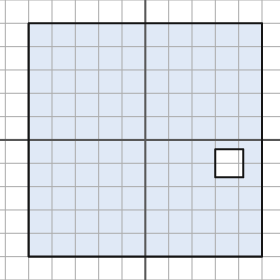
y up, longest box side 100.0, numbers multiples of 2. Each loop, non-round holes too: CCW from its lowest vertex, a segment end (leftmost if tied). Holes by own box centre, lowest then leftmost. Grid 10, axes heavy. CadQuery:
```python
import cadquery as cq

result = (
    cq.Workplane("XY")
    .moveTo(-50.0, -50.0)
    .lineTo(50.0, -50.0)
    .lineTo(50.0, 50.0)
    .lineTo(-50.0, 50.0)
    .close()
    .moveTo(30.0, -16.0)
    .lineTo(42.0, -16.0)
    .lineTo(42.0, -4.0)
    .lineTo(30.0, -4.0)
    .close()
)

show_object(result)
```